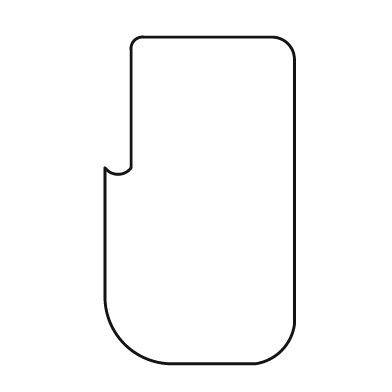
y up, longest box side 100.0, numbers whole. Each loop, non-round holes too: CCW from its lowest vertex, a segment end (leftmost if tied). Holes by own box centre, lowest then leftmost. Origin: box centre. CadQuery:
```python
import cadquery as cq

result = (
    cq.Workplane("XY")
    .moveTo(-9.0, -50.0)
    .lineTo(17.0, -50.0)
    .threePointArc((25.0, -46.0), (29.0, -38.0))
    .lineTo(29.0, 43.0)
    .threePointArc((27.0, 48.0), (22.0, 50.0))
    .lineTo(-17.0, 50.0)
    .threePointArc((-20.0, 49.0), (-21.0, 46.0))
    .lineTo(-21.0, 10.0)
    .threePointArc((-25.0, 8.0), (-29.0, 10.0))
    .lineTo(-29.0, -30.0)
    .threePointArc((-23.0, -44.0), (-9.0, -50.0))
    .close()
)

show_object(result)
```